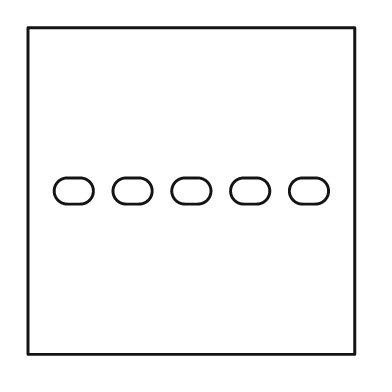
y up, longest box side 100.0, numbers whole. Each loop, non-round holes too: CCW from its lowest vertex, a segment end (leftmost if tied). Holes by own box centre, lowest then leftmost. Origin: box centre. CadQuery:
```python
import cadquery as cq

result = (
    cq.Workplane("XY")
    .moveTo(-50.0, -50.0)
    .lineTo(50.0, -50.0)
    .lineTo(50.0, 50.0)
    .lineTo(-50.0, 50.0)
    .close()
    .moveTo(-38.0, -4.0)
    .lineTo(-34.0, -4.0)
    .threePointArc((-30.0, 0.0), (-34.0, 4.0))
    .lineTo(-38.0, 4.0)
    .threePointArc((-42.0, 0.0), (-38.0, -4.0))
    .close()
    .moveTo(-20.0, -4.0)
    .lineTo(-16.0, -4.0)
    .threePointArc((-12.0, 0.0), (-16.0, 4.0))
    .lineTo(-20.0, 4.0)
    .threePointArc((-24.0, 0.0), (-20.0, -4.0))
    .close()
    .moveTo(-2.0, -4.0)
    .lineTo(2.0, -4.0)
    .threePointArc((6.0, 0.0), (2.0, 4.0))
    .lineTo(-2.0, 4.0)
    .threePointArc((-6.0, 0.0), (-2.0, -4.0))
    .close()
    .moveTo(16.0, -4.0)
    .lineTo(20.0, -4.0)
    .threePointArc((24.0, 0.0), (20.0, 4.0))
    .lineTo(16.0, 4.0)
    .threePointArc((12.0, 0.0), (16.0, -4.0))
    .close()
    .moveTo(34.0, -4.0)
    .lineTo(38.0, -4.0)
    .threePointArc((42.0, 0.0), (38.0, 4.0))
    .lineTo(34.0, 4.0)
    .threePointArc((30.0, 0.0), (34.0, -4.0))
    .close()
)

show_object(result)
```